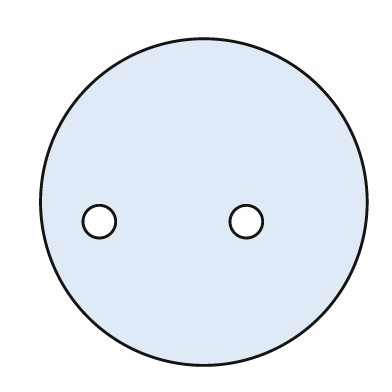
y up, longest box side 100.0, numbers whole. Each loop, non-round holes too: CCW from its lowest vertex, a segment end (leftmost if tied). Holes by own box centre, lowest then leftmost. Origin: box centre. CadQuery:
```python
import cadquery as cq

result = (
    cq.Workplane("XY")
    .moveTo(0.0, 0.0)
    .circle(50.0)
    .moveTo(-32.0, -6.0)
    .circle(5.0)
    .moveTo(13.0, -6.0)
    .circle(5.0)
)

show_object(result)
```